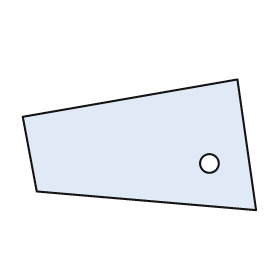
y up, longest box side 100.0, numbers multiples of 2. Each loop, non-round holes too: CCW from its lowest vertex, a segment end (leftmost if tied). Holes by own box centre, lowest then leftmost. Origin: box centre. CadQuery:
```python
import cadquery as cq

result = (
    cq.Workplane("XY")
    .moveTo(50.0, -28.0)
    .lineTo(42.0, 28.0)
    .lineTo(-50.0, 12.0)
    .lineTo(-44.0, -20.0)
    .close()
    .moveTo(30.0, -8.0)
    .circle(4.0)
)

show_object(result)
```